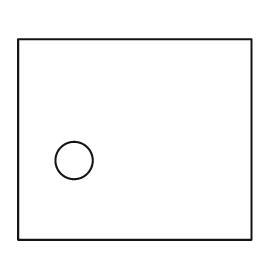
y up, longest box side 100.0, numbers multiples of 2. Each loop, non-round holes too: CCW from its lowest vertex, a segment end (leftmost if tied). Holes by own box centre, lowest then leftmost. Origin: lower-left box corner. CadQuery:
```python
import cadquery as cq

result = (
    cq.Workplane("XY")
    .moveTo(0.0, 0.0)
    .lineTo(100.0, 0.0)
    .lineTo(100.0, 86.0)
    .lineTo(0.0, 86.0)
    .close()
    .moveTo(24.0, 34.0)
    .circle(8.0)
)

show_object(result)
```